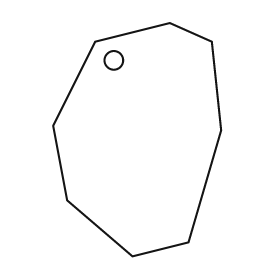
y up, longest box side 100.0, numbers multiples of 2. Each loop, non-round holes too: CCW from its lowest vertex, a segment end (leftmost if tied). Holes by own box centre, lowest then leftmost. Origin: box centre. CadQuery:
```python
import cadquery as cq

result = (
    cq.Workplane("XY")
    .moveTo(-2.0, -50.0)
    .lineTo(22.0, -44.0)
    .lineTo(36.0, 4.0)
    .lineTo(32.0, 42.0)
    .lineTo(14.0, 50.0)
    .lineTo(-18.0, 42.0)
    .lineTo(-36.0, 6.0)
    .lineTo(-30.0, -26.0)
    .close()
    .moveTo(-10.0, 34.0)
    .circle(4.0)
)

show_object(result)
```